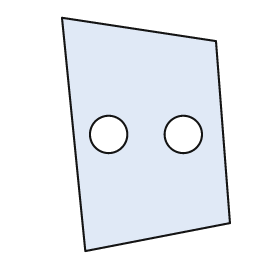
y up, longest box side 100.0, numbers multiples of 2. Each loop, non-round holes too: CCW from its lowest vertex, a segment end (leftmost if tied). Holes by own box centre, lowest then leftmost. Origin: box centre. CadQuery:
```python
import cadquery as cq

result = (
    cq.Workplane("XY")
    .moveTo(-26.0, -50.0)
    .lineTo(36.0, -38.0)
    .lineTo(30.0, 40.0)
    .lineTo(-36.0, 50.0)
    .close()
    .moveTo(-16.0, 0.0)
    .circle(8.0)
    .moveTo(16.0, 0.0)
    .circle(8.0)
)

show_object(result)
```